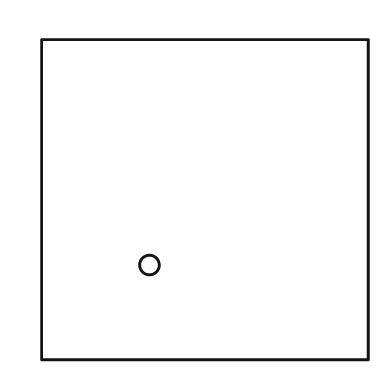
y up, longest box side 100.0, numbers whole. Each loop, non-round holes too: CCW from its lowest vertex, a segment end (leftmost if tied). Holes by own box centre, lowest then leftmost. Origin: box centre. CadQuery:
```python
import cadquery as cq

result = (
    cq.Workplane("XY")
    .moveTo(-50.0, -49.0)
    .lineTo(50.0, -49.0)
    .lineTo(50.0, 49.0)
    .lineTo(-50.0, 49.0)
    .close()
    .moveTo(-17.0, -20.0)
    .circle(3.0)
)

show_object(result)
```